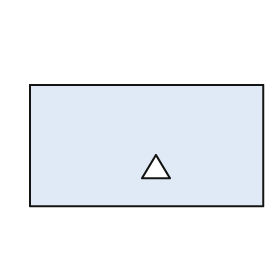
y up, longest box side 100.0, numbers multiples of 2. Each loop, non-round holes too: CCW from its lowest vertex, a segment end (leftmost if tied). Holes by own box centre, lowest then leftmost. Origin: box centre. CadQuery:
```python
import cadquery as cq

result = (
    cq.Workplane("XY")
    .moveTo(-50.0, -26.0)
    .lineTo(50.0, -26.0)
    .lineTo(50.0, 26.0)
    .lineTo(-50.0, 26.0)
    .close()
    .moveTo(-2.0, -14.0)
    .lineTo(10.0, -14.0)
    .lineTo(4.0, -4.0)
    .close()
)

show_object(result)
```